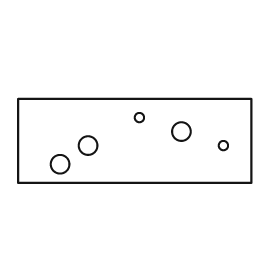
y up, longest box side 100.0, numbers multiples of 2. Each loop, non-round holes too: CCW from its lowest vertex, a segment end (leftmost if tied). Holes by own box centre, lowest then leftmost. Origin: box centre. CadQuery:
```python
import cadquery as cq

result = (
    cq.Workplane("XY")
    .moveTo(-50.0, -18.0)
    .lineTo(50.0, -18.0)
    .lineTo(50.0, 18.0)
    .lineTo(-50.0, 18.0)
    .close()
    .moveTo(-32.0, -10.0)
    .circle(4.0)
    .moveTo(-20.0, -2.0)
    .circle(4.0)
    .moveTo(38.0, -2.0)
    .circle(2.0)
    .moveTo(20.0, 4.0)
    .circle(4.0)
    .moveTo(2.0, 10.0)
    .circle(2.0)
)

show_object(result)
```